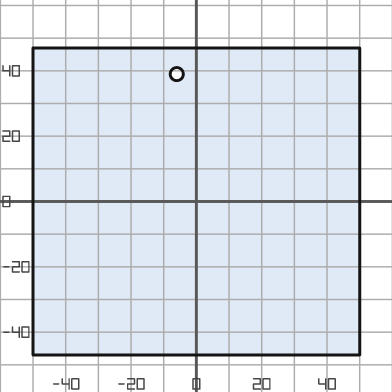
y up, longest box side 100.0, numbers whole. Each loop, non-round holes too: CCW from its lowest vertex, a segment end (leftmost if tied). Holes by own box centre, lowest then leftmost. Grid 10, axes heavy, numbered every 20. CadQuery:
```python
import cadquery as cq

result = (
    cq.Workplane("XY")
    .moveTo(-50.0, -47.0)
    .lineTo(50.0, -47.0)
    .lineTo(50.0, 47.0)
    .lineTo(-50.0, 47.0)
    .close()
    .moveTo(-6.0, 39.0)
    .circle(2.0)
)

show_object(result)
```